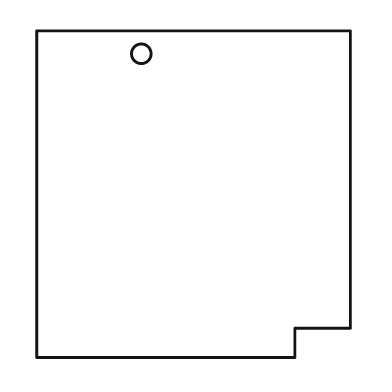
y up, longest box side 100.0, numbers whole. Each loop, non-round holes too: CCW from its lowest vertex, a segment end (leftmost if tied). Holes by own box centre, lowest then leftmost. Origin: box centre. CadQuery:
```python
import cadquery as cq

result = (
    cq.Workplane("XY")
    .moveTo(-48.0, -50.0)
    .lineTo(31.0, -50.0)
    .lineTo(31.0, -41.0)
    .lineTo(48.0, -41.0)
    .lineTo(48.0, 50.0)
    .lineTo(-48.0, 50.0)
    .close()
    .moveTo(-16.0, 43.0)
    .circle(3.0)
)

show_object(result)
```